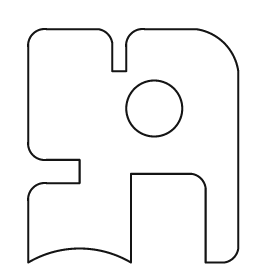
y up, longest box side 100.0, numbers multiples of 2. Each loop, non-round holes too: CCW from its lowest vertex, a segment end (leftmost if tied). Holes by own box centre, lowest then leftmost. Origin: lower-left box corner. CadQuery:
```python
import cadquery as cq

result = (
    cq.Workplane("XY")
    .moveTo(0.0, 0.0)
    .threePointArc((22.0, 6.0), (44.0, 0.0))
    .lineTo(44.0, 38.0)
    .lineTo(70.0, 38.0)
    .threePointArc((74.0, 36.0), (76.0, 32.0))
    .lineTo(76.0, 0.0)
    .lineTo(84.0, 0.0)
    .threePointArc((88.0, 2.0), (90.0, 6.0))
    .lineTo(90.0, 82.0)
    .threePointArc((84.0, 94.0), (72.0, 100.0))
    .lineTo(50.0, 100.0)
    .threePointArc((44.0, 98.0), (42.0, 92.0))
    .lineTo(42.0, 82.0)
    .lineTo(36.0, 82.0)
    .lineTo(36.0, 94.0)
    .threePointArc((34.0, 98.0), (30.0, 100.0))
    .lineTo(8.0, 100.0)
    .threePointArc((2.0, 98.0), (0.0, 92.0))
    .lineTo(0.0, 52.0)
    .threePointArc((2.0, 46.0), (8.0, 44.0))
    .lineTo(22.0, 44.0)
    .lineTo(22.0, 34.0)
    .lineTo(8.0, 34.0)
    .threePointArc((2.0, 32.0), (0.0, 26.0))
    .close()
    .moveTo(54.0, 66.0)
    .circle(12.0)
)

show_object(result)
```